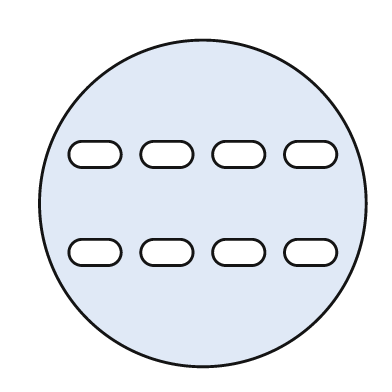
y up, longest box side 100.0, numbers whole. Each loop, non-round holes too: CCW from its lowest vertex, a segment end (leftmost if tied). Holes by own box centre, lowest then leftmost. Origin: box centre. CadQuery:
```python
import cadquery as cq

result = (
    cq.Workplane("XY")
    .moveTo(0.0, 0.0)
    .circle(50.0)
    .moveTo(-37.0, -19.0)
    .lineTo(-29.0, -19.0)
    .threePointArc((-25.0, -15.0), (-29.0, -11.0))
    .lineTo(-37.0, -11.0)
    .threePointArc((-41.0, -15.0), (-37.0, -19.0))
    .close()
    .moveTo(-15.0, -19.0)
    .lineTo(-7.0, -19.0)
    .threePointArc((-3.0, -15.0), (-7.0, -11.0))
    .lineTo(-15.0, -11.0)
    .threePointArc((-19.0, -15.0), (-15.0, -19.0))
    .close()
    .moveTo(7.0, -19.0)
    .lineTo(15.0, -19.0)
    .threePointArc((19.0, -15.0), (15.0, -11.0))
    .lineTo(7.0, -11.0)
    .threePointArc((3.0, -15.0), (7.0, -19.0))
    .close()
    .moveTo(29.0, -19.0)
    .lineTo(37.0, -19.0)
    .threePointArc((41.0, -15.0), (37.0, -11.0))
    .lineTo(29.0, -11.0)
    .threePointArc((25.0, -15.0), (29.0, -19.0))
    .close()
    .moveTo(-37.0, 11.0)
    .lineTo(-29.0, 11.0)
    .threePointArc((-25.0, 15.0), (-29.0, 19.0))
    .lineTo(-37.0, 19.0)
    .threePointArc((-41.0, 15.0), (-37.0, 11.0))
    .close()
    .moveTo(-15.0, 11.0)
    .lineTo(-7.0, 11.0)
    .threePointArc((-3.0, 15.0), (-7.0, 19.0))
    .lineTo(-15.0, 19.0)
    .threePointArc((-19.0, 15.0), (-15.0, 11.0))
    .close()
    .moveTo(7.0, 11.0)
    .lineTo(15.0, 11.0)
    .threePointArc((19.0, 15.0), (15.0, 19.0))
    .lineTo(7.0, 19.0)
    .threePointArc((3.0, 15.0), (7.0, 11.0))
    .close()
    .moveTo(29.0, 11.0)
    .lineTo(37.0, 11.0)
    .threePointArc((41.0, 15.0), (37.0, 19.0))
    .lineTo(29.0, 19.0)
    .threePointArc((25.0, 15.0), (29.0, 11.0))
    .close()
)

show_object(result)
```